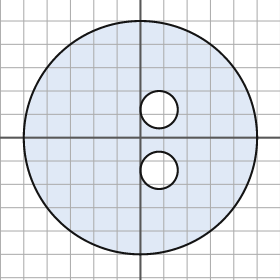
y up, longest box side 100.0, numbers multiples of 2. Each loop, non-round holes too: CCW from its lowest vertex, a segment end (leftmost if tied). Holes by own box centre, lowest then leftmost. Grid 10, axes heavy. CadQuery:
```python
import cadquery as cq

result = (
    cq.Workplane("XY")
    .moveTo(0.0, 0.0)
    .circle(50.0)
    .moveTo(8.0, -14.0)
    .circle(8.0)
    .moveTo(8.0, 12.0)
    .circle(8.0)
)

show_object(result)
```